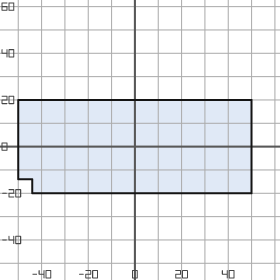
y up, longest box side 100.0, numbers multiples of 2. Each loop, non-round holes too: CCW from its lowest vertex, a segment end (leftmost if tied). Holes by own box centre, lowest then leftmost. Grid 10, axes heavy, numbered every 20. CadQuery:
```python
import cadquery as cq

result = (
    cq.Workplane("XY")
    .moveTo(-44.0, -20.0)
    .lineTo(50.0, -20.0)
    .lineTo(50.0, 20.0)
    .lineTo(-50.0, 20.0)
    .lineTo(-50.0, -14.0)
    .lineTo(-44.0, -14.0)
    .close()
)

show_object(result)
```